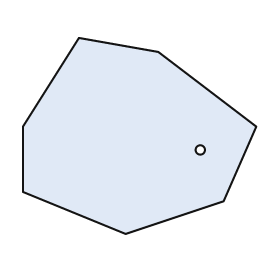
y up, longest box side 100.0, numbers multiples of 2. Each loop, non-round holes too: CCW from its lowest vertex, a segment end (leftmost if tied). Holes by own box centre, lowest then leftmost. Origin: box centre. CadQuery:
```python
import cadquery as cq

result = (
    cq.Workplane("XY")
    .moveTo(-6.0, -42.0)
    .lineTo(36.0, -28.0)
    .lineTo(50.0, 4.0)
    .lineTo(8.0, 36.0)
    .lineTo(-26.0, 42.0)
    .lineTo(-50.0, 4.0)
    .lineTo(-50.0, -24.0)
    .close()
    .moveTo(26.0, -6.0)
    .circle(2.0)
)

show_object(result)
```